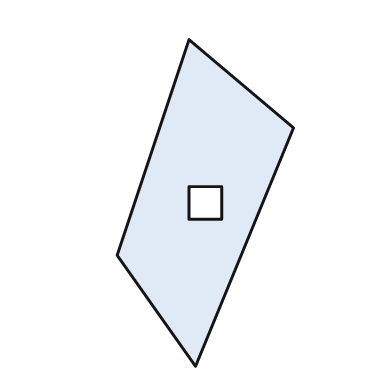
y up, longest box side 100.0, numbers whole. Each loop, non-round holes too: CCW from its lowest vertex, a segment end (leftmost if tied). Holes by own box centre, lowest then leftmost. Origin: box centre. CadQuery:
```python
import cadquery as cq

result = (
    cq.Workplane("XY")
    .moveTo(-3.0, -50.0)
    .lineTo(27.0, 23.0)
    .lineTo(-5.0, 50.0)
    .lineTo(-27.0, -16.0)
    .close()
    .moveTo(-5.0, -5.0)
    .lineTo(5.0, -5.0)
    .lineTo(5.0, 5.0)
    .lineTo(-5.0, 5.0)
    .close()
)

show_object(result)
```